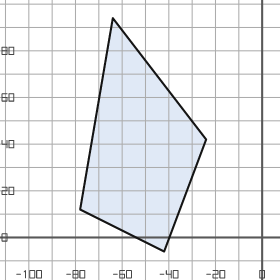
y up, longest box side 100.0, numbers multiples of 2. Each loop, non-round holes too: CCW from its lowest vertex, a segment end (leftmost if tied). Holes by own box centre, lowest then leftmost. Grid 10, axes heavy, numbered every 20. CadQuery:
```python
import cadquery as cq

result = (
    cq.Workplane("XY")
    .moveTo(-42.0, -6.0)
    .lineTo(-24.0, 42.0)
    .lineTo(-64.0, 94.0)
    .lineTo(-78.0, 12.0)
    .close()
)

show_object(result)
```